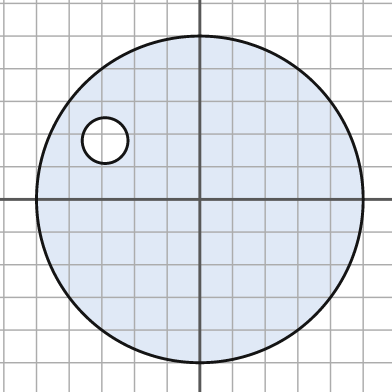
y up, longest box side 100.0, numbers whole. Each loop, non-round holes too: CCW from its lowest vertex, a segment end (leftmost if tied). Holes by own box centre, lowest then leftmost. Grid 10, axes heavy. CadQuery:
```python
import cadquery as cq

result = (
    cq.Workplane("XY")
    .moveTo(0.0, 0.0)
    .circle(50.0)
    .moveTo(-29.0, 18.0)
    .circle(7.0)
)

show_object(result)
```